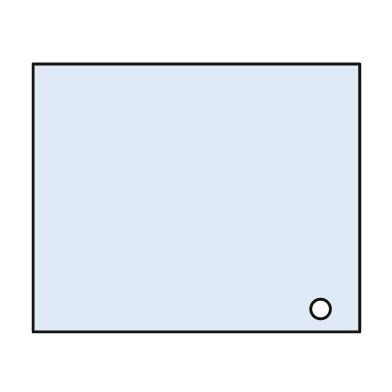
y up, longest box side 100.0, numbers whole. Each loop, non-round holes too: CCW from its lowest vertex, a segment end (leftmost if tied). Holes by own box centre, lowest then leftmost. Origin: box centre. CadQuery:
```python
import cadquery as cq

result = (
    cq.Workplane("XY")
    .moveTo(-50.0, -41.0)
    .lineTo(50.0, -41.0)
    .lineTo(50.0, 41.0)
    .lineTo(-50.0, 41.0)
    .close()
    .moveTo(38.0, -34.0)
    .circle(3.0)
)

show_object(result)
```